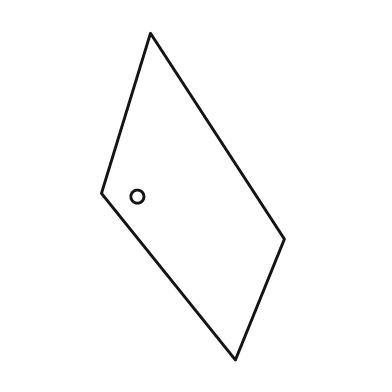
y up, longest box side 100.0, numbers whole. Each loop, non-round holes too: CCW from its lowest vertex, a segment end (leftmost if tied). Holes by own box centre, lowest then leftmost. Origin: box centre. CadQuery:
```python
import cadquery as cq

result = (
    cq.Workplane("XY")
    .moveTo(13.0, -50.0)
    .lineTo(28.0, -13.0)
    .lineTo(-13.0, 50.0)
    .lineTo(-28.0, 1.0)
    .close()
    .moveTo(-17.0, 0.0)
    .circle(2.0)
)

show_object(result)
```